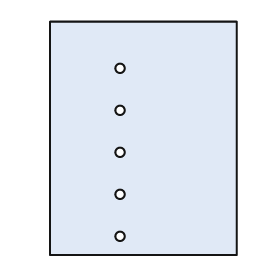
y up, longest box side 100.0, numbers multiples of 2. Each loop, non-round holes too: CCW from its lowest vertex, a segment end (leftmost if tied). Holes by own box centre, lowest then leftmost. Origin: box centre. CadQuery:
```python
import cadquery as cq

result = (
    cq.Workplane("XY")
    .moveTo(-40.0, -50.0)
    .lineTo(40.0, -50.0)
    .lineTo(40.0, 50.0)
    .lineTo(-40.0, 50.0)
    .close()
    .moveTo(-10.0, -42.0)
    .circle(2.0)
    .moveTo(-10.0, -24.0)
    .circle(2.0)
    .moveTo(-10.0, -6.0)
    .circle(2.0)
    .moveTo(-10.0, 12.0)
    .circle(2.0)
    .moveTo(-10.0, 30.0)
    .circle(2.0)
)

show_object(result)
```